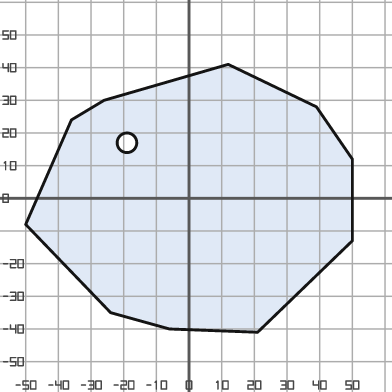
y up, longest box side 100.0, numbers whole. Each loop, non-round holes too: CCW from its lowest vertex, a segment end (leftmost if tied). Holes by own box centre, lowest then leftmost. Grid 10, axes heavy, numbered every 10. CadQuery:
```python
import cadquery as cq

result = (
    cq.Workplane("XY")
    .moveTo(21.0, -41.0)
    .lineTo(50.0, -13.0)
    .lineTo(50.0, 12.0)
    .lineTo(39.0, 28.0)
    .lineTo(12.0, 41.0)
    .lineTo(-26.0, 30.0)
    .lineTo(-36.0, 24.0)
    .lineTo(-50.0, -8.0)
    .lineTo(-24.0, -35.0)
    .lineTo(-6.0, -40.0)
    .close()
    .moveTo(-19.0, 17.0)
    .circle(3.0)
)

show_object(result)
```